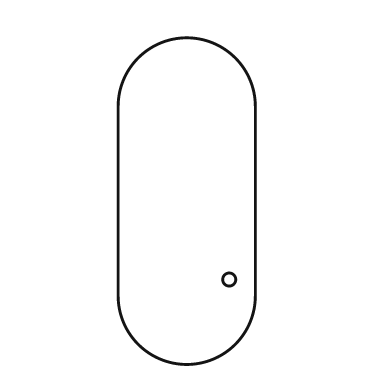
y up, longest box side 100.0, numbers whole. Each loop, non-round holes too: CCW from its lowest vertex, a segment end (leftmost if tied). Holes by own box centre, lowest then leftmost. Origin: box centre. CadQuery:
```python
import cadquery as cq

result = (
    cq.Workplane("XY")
    .moveTo(-21.0, -29.0)
    .threePointArc((0.0, -50.0), (21.0, -29.0))
    .lineTo(21.0, 29.0)
    .threePointArc((0.0, 50.0), (-21.0, 29.0))
    .close()
    .moveTo(13.0, -24.0)
    .circle(2.0)
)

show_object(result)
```